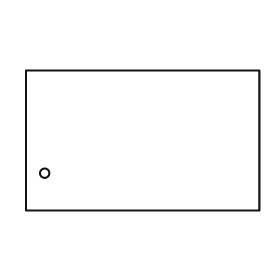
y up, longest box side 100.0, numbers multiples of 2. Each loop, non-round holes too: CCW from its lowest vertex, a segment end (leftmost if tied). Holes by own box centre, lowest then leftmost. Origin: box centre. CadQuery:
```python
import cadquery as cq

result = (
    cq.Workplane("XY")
    .moveTo(-50.0, -30.0)
    .lineTo(50.0, -30.0)
    .lineTo(50.0, 30.0)
    .lineTo(-50.0, 30.0)
    .close()
    .moveTo(-42.0, -14.0)
    .circle(2.0)
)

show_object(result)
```